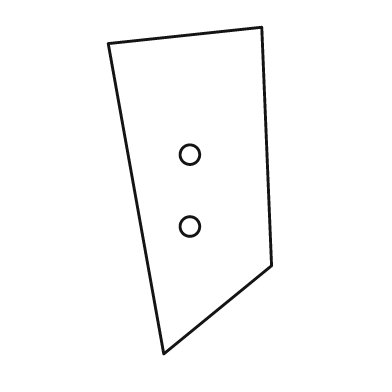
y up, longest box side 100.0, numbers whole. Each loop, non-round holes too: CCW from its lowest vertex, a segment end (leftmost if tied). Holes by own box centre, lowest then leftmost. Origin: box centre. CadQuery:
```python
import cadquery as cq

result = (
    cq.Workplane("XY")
    .moveTo(-8.0, -50.0)
    .lineTo(25.0, -23.0)
    .lineTo(22.0, 50.0)
    .lineTo(-25.0, 45.0)
    .close()
    .moveTo(0.0, -11.0)
    .circle(3.0)
    .moveTo(0.0, 11.0)
    .circle(3.0)
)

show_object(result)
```